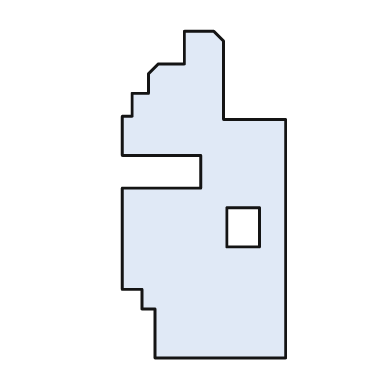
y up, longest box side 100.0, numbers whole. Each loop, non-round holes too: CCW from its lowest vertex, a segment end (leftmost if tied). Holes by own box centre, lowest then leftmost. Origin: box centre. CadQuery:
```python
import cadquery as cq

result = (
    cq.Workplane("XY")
    .moveTo(-15.0, -50.0)
    .lineTo(25.0, -50.0)
    .lineTo(25.0, 23.0)
    .lineTo(6.0, 23.0)
    .lineTo(6.0, 47.0)
    .lineTo(3.0, 50.0)
    .lineTo(-6.0, 50.0)
    .lineTo(-6.0, 40.0)
    .lineTo(-14.0, 40.0)
    .lineTo(-17.0, 37.0)
    .lineTo(-17.0, 31.0)
    .lineTo(-22.0, 31.0)
    .lineTo(-22.0, 24.0)
    .lineTo(-25.0, 24.0)
    .lineTo(-25.0, 12.0)
    .lineTo(-1.0, 12.0)
    .lineTo(-1.0, 2.0)
    .lineTo(-25.0, 2.0)
    .lineTo(-25.0, -29.0)
    .lineTo(-19.0, -29.0)
    .lineTo(-19.0, -35.0)
    .lineTo(-15.0, -35.0)
    .close()
    .moveTo(7.0, -16.0)
    .lineTo(17.0, -16.0)
    .lineTo(17.0, -4.0)
    .lineTo(7.0, -4.0)
    .close()
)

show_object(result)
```